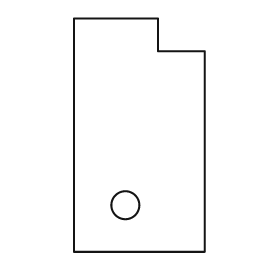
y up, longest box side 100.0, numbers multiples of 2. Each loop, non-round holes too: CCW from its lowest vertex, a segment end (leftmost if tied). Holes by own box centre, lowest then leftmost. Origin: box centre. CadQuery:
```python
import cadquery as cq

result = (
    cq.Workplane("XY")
    .moveTo(-28.0, -50.0)
    .lineTo(28.0, -50.0)
    .lineTo(28.0, 36.0)
    .lineTo(8.0, 36.0)
    .lineTo(8.0, 50.0)
    .lineTo(-28.0, 50.0)
    .close()
    .moveTo(-6.0, -30.0)
    .circle(6.0)
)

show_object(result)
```